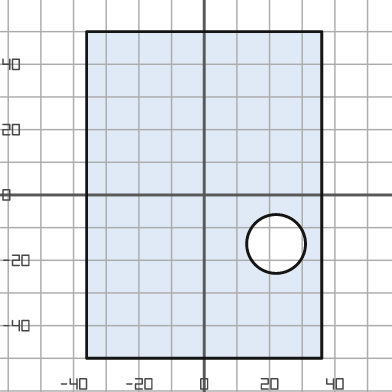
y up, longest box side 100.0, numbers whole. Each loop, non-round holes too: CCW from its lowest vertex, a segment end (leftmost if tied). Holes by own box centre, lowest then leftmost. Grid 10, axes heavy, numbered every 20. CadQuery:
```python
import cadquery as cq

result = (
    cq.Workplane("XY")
    .moveTo(-36.0, -50.0)
    .lineTo(36.0, -50.0)
    .lineTo(36.0, 50.0)
    .lineTo(-36.0, 50.0)
    .close()
    .moveTo(22.0, -15.0)
    .circle(9.0)
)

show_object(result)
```